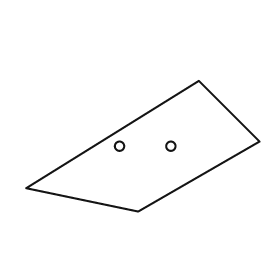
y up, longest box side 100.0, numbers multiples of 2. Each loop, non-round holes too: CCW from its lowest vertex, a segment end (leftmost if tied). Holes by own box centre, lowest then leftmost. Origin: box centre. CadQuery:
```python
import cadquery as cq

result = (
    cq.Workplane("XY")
    .moveTo(-2.0, -28.0)
    .lineTo(50.0, 2.0)
    .lineTo(24.0, 28.0)
    .lineTo(-50.0, -18.0)
    .close()
    .moveTo(-10.0, 0.0)
    .circle(2.0)
    .moveTo(12.0, 0.0)
    .circle(2.0)
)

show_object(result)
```